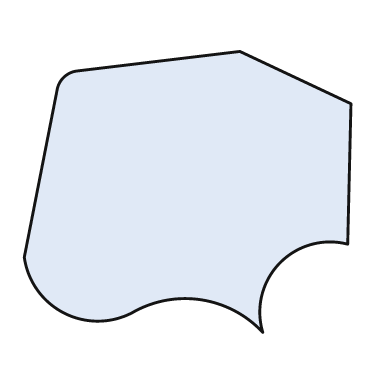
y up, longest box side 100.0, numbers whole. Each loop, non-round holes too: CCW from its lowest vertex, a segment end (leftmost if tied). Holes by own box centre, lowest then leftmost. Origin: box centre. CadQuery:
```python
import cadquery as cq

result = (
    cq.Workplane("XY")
    .moveTo(23.0, -43.0)
    .threePointArc((28.0, -22.0), (49.0, -16.0))
    .lineTo(50.0, 27.0)
    .lineTo(16.0, 43.0)
    .lineTo(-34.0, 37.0)
    .threePointArc((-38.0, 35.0), (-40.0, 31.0))
    .lineTo(-50.0, -20.0)
    .threePointArc((-38.0, -37.0), (-17.0, -37.0))
    .threePointArc((4.0, -33.0), (23.0, -43.0))
    .close()
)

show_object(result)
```